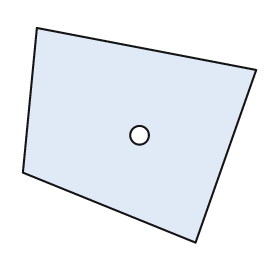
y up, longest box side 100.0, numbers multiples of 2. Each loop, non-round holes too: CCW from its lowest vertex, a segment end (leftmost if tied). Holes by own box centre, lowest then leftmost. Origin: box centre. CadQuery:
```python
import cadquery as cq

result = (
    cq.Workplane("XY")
    .moveTo(24.0, -46.0)
    .lineTo(50.0, 28.0)
    .lineTo(-44.0, 46.0)
    .lineTo(-50.0, -16.0)
    .close()
    .moveTo(0.0, 0.0)
    .circle(4.0)
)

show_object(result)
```